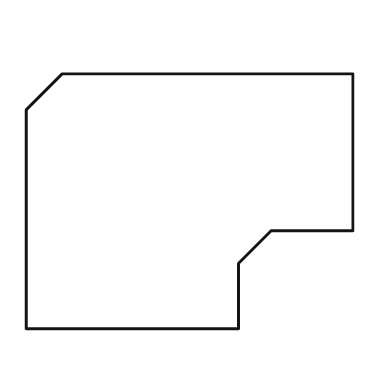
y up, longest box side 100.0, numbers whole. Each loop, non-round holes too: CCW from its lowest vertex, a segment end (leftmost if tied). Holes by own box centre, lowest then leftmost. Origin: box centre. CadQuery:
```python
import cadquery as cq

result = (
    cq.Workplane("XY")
    .moveTo(-50.0, -39.0)
    .lineTo(15.0, -39.0)
    .lineTo(15.0, -19.0)
    .lineTo(25.0, -9.0)
    .lineTo(50.0, -9.0)
    .lineTo(50.0, 39.0)
    .lineTo(-39.0, 39.0)
    .lineTo(-50.0, 28.0)
    .close()
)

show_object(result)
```